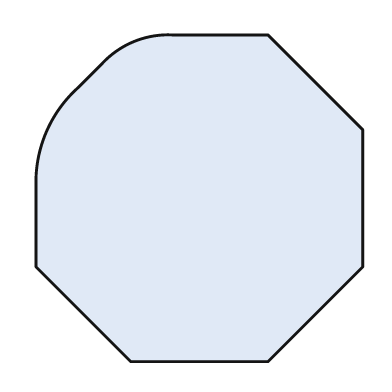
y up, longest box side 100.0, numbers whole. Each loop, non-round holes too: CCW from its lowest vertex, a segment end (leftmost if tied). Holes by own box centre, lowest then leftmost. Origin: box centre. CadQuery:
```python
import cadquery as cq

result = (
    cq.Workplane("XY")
    .moveTo(-21.0, -50.0)
    .lineTo(21.0, -50.0)
    .lineTo(50.0, -21.0)
    .lineTo(50.0, 21.0)
    .lineTo(21.0, 50.0)
    .lineTo(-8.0, 50.0)
    .threePointArc((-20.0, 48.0), (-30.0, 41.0))
    .lineTo(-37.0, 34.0)
    .threePointArc((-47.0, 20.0), (-50.0, 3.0))
    .lineTo(-50.0, -21.0)
    .close()
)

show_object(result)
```